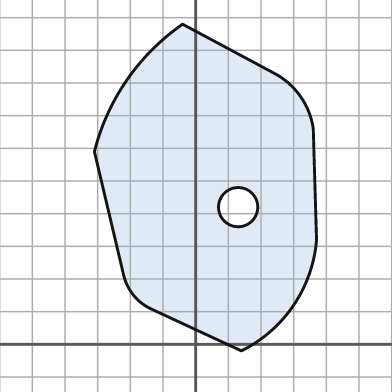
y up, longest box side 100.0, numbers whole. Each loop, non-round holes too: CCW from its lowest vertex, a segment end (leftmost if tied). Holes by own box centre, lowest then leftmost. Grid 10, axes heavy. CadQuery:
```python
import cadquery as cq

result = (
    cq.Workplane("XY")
    .moveTo(14.0, -2.0)
    .threePointArc((30.0, 12.0), (37.0, 32.0))
    .lineTo(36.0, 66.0)
    .threePointArc((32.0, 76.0), (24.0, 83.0))
    .lineTo(-4.0, 98.0)
    .threePointArc((-21.0, 81.0), (-31.0, 59.0))
    .lineTo(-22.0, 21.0)
    .threePointArc((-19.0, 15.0), (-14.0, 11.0))
    .close()
    .moveTo(13.0, 42.0)
    .circle(6.0)
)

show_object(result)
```